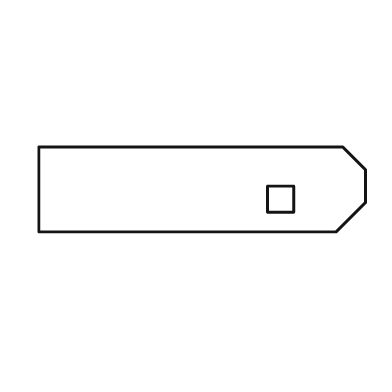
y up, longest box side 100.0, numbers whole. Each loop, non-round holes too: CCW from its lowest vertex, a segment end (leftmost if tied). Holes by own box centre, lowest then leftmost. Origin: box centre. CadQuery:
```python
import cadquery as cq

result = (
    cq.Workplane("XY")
    .moveTo(-50.0, -13.0)
    .lineTo(41.0, -13.0)
    .lineTo(50.0, -4.0)
    .lineTo(50.0, 6.0)
    .lineTo(43.0, 13.0)
    .lineTo(-50.0, 13.0)
    .close()
    .moveTo(20.0, -7.0)
    .lineTo(28.0, -7.0)
    .lineTo(28.0, 1.0)
    .lineTo(20.0, 1.0)
    .close()
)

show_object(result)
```